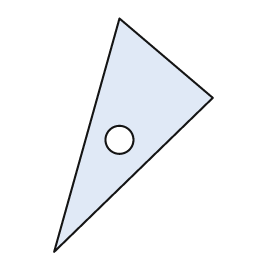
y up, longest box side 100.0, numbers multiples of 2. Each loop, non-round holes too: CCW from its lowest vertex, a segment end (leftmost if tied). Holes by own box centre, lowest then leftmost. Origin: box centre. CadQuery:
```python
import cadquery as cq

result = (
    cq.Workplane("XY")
    .moveTo(-34.0, -50.0)
    .lineTo(34.0, 16.0)
    .lineTo(-6.0, 50.0)
    .close()
    .moveTo(-6.0, -2.0)
    .circle(6.0)
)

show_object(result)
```